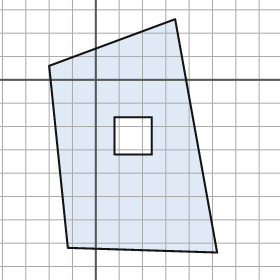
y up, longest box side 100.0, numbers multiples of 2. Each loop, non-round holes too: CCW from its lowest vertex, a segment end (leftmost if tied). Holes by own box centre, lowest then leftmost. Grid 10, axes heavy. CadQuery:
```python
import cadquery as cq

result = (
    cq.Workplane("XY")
    .moveTo(52.0, -74.0)
    .lineTo(34.0, 26.0)
    .lineTo(-20.0, 6.0)
    .lineTo(-12.0, -72.0)
    .close()
    .moveTo(8.0, -32.0)
    .lineTo(24.0, -32.0)
    .lineTo(24.0, -16.0)
    .lineTo(8.0, -16.0)
    .close()
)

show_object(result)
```